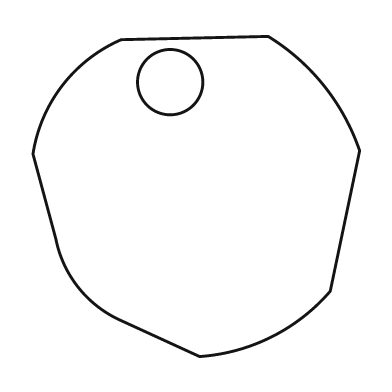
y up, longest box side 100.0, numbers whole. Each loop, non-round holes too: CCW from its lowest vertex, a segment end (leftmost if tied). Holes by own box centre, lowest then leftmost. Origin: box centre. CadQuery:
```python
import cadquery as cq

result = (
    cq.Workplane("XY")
    .moveTo(1.0, -49.0)
    .threePointArc((23.0, -43.0), (41.0, -29.0))
    .lineTo(50.0, 14.0)
    .threePointArc((39.0, 34.0), (22.0, 49.0))
    .lineTo(-23.0, 48.0)
    .threePointArc((-41.0, 34.0), (-50.0, 13.0))
    .lineTo(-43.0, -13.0)
    .threePointArc((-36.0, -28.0), (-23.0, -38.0))
    .close()
    .moveTo(-8.0, 35.0)
    .circle(10.0)
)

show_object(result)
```